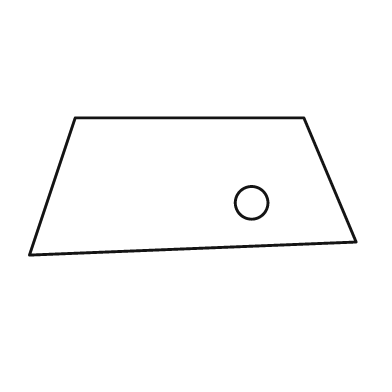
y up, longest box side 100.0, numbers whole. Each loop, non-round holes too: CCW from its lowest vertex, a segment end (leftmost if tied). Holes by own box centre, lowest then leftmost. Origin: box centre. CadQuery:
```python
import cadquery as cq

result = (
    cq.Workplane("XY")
    .moveTo(-50.0, -21.0)
    .lineTo(50.0, -17.0)
    .lineTo(34.0, 21.0)
    .lineTo(-36.0, 21.0)
    .close()
    .moveTo(18.0, -5.0)
    .circle(5.0)
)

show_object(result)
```